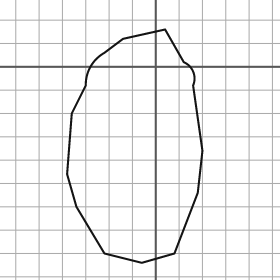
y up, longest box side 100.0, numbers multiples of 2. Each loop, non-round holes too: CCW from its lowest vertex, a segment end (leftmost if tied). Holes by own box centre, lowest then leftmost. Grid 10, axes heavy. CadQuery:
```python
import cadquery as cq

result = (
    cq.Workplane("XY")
    .moveTo(-6.0, -84.0)
    .lineTo(8.0, -80.0)
    .lineTo(18.0, -54.0)
    .lineTo(20.0, -36.0)
    .lineTo(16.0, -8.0)
    .threePointArc((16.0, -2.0), (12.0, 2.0))
    .lineTo(4.0, 16.0)
    .lineTo(-14.0, 12.0)
    .lineTo(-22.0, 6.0)
    .threePointArc((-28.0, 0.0), (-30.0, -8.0))
    .lineTo(-36.0, -20.0)
    .lineTo(-38.0, -46.0)
    .lineTo(-34.0, -60.0)
    .lineTo(-22.0, -80.0)
    .close()
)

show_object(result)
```